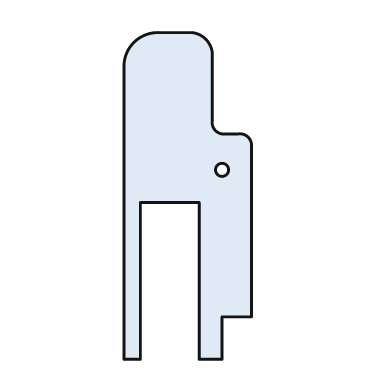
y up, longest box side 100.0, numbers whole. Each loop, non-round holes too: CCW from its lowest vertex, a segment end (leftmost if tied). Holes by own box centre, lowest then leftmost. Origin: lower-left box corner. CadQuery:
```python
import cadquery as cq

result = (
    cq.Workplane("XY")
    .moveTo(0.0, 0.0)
    .lineTo(5.0, 0.0)
    .lineTo(5.0, 48.0)
    .lineTo(23.0, 48.0)
    .lineTo(23.0, 0.0)
    .lineTo(30.0, 0.0)
    .lineTo(30.0, 13.0)
    .lineTo(39.0, 13.0)
    .lineTo(39.0, 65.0)
    .threePointArc((38.0, 68.0), (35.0, 69.0))
    .lineTo(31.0, 69.0)
    .threePointArc((28.0, 70.0), (27.0, 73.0))
    .lineTo(27.0, 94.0)
    .threePointArc((25.0, 98.0), (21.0, 100.0))
    .lineTo(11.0, 100.0)
    .threePointArc((3.0, 97.0), (0.0, 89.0))
    .close()
    .moveTo(30.0, 58.0)
    .circle(2.0)
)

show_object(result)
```